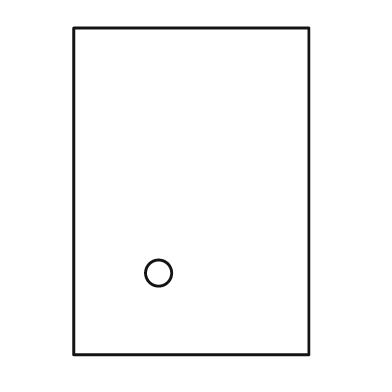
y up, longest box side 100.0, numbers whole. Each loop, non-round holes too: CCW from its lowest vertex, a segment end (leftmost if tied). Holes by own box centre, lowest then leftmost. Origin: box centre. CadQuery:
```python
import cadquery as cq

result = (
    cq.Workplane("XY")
    .moveTo(-36.0, -50.0)
    .lineTo(36.0, -50.0)
    .lineTo(36.0, 50.0)
    .lineTo(-36.0, 50.0)
    .close()
    .moveTo(-10.0, -25.0)
    .circle(4.0)
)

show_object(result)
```